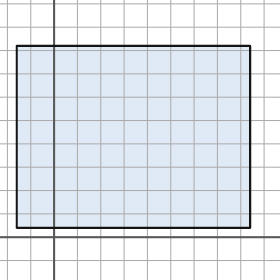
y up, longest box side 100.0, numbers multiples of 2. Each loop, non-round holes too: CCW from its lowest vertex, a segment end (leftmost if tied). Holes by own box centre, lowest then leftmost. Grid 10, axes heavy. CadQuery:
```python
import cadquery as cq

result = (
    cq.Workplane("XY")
    .moveTo(-16.0, 4.0)
    .lineTo(84.0, 4.0)
    .lineTo(84.0, 82.0)
    .lineTo(-16.0, 82.0)
    .close()
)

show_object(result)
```